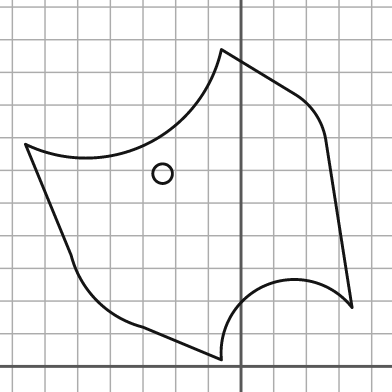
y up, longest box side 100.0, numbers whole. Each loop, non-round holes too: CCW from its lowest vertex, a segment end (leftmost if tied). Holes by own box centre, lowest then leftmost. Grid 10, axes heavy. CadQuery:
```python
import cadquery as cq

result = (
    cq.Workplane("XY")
    .moveTo(-6.0, 2.0)
    .threePointArc((8.0, 25.0), (34.0, 18.0))
    .lineTo(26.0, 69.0)
    .threePointArc((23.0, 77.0), (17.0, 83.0))
    .lineTo(-6.0, 97.0)
    .threePointArc((-29.0, 68.0), (-66.0, 68.0))
    .lineTo(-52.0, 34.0)
    .threePointArc((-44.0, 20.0), (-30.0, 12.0))
    .close()
    .moveTo(-24.0, 59.0)
    .circle(3.0)
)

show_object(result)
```